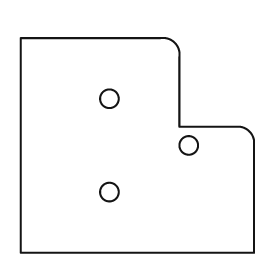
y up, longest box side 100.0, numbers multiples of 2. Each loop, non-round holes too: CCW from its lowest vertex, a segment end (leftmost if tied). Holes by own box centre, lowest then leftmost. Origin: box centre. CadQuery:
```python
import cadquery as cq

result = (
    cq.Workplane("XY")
    .moveTo(-50.0, -46.0)
    .lineTo(50.0, -46.0)
    .lineTo(50.0, 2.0)
    .threePointArc((48.0, 6.0), (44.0, 8.0))
    .lineTo(18.0, 8.0)
    .lineTo(18.0, 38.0)
    .threePointArc((16.0, 44.0), (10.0, 46.0))
    .lineTo(-50.0, 46.0)
    .close()
    .moveTo(-12.0, -20.0)
    .circle(4.0)
    .moveTo(22.0, 0.0)
    .circle(4.0)
    .moveTo(-12.0, 20.0)
    .circle(4.0)
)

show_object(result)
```